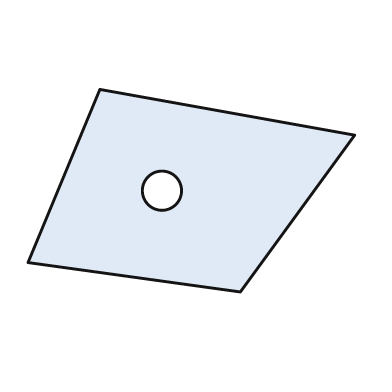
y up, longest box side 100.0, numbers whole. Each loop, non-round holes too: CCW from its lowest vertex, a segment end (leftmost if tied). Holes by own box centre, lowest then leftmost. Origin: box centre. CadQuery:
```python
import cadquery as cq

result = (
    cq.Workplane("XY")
    .moveTo(15.0, -31.0)
    .lineTo(50.0, 17.0)
    .lineTo(-28.0, 31.0)
    .lineTo(-50.0, -22.0)
    .close()
    .moveTo(-9.0, 0.0)
    .circle(6.0)
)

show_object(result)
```